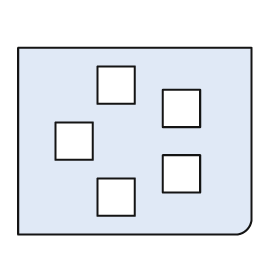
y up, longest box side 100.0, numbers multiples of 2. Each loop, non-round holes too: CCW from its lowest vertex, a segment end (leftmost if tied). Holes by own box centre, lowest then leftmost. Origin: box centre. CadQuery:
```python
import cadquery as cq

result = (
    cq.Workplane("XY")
    .moveTo(-50.0, -40.0)
    .lineTo(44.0, -40.0)
    .threePointArc((48.0, -38.0), (50.0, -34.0))
    .lineTo(50.0, 40.0)
    .lineTo(-50.0, 40.0)
    .close()
    .moveTo(-16.0, -32.0)
    .lineTo(0.0, -32.0)
    .lineTo(0.0, -16.0)
    .lineTo(-16.0, -16.0)
    .close()
    .moveTo(12.0, -22.0)
    .lineTo(28.0, -22.0)
    .lineTo(28.0, -6.0)
    .lineTo(12.0, -6.0)
    .close()
    .moveTo(-34.0, -8.0)
    .lineTo(-18.0, -8.0)
    .lineTo(-18.0, 8.0)
    .lineTo(-34.0, 8.0)
    .close()
    .moveTo(12.0, 6.0)
    .lineTo(28.0, 6.0)
    .lineTo(28.0, 22.0)
    .lineTo(12.0, 22.0)
    .close()
    .moveTo(-16.0, 16.0)
    .lineTo(0.0, 16.0)
    .lineTo(0.0, 32.0)
    .lineTo(-16.0, 32.0)
    .close()
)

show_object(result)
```